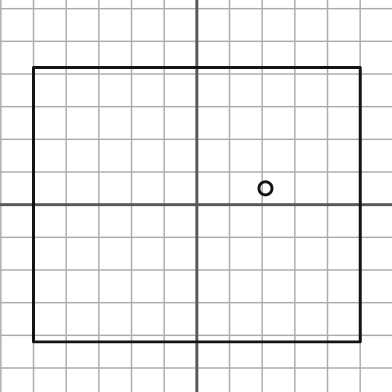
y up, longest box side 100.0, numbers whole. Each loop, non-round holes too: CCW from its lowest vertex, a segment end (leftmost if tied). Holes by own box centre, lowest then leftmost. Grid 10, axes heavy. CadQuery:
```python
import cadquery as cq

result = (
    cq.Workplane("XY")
    .moveTo(-50.0, -42.0)
    .lineTo(50.0, -42.0)
    .lineTo(50.0, 42.0)
    .lineTo(-50.0, 42.0)
    .close()
    .moveTo(21.0, 5.0)
    .circle(2.0)
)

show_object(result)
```